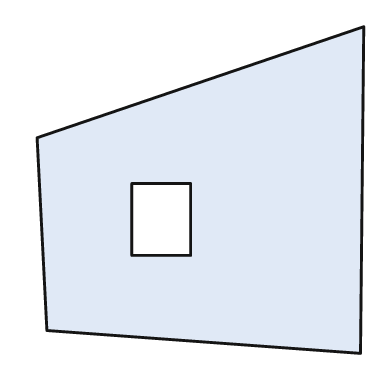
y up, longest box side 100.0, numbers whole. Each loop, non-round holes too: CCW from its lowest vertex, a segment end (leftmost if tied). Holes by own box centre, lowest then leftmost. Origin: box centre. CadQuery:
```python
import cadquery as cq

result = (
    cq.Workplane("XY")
    .moveTo(49.0, -50.0)
    .lineTo(50.0, 50.0)
    .lineTo(-50.0, 16.0)
    .lineTo(-47.0, -43.0)
    .close()
    .moveTo(-21.0, -20.0)
    .lineTo(-3.0, -20.0)
    .lineTo(-3.0, 2.0)
    .lineTo(-21.0, 2.0)
    .close()
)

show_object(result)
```